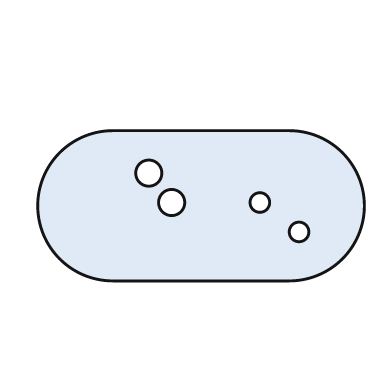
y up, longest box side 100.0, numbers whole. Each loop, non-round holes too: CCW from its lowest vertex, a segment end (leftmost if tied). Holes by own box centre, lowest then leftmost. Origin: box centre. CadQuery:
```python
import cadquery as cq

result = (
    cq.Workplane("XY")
    .moveTo(-27.0, -23.0)
    .lineTo(27.0, -23.0)
    .threePointArc((50.0, 0.0), (27.0, 23.0))
    .lineTo(-27.0, 23.0)
    .threePointArc((-50.0, 0.0), (-27.0, -23.0))
    .close()
    .moveTo(30.0, -8.0)
    .circle(3.0)
    .moveTo(-9.0, 1.0)
    .circle(4.0)
    .moveTo(18.0, 1.0)
    .circle(3.0)
    .moveTo(-16.0, 10.0)
    .circle(4.0)
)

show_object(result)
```